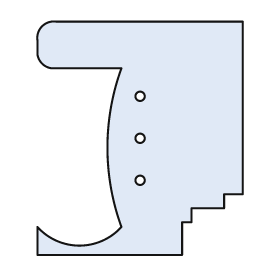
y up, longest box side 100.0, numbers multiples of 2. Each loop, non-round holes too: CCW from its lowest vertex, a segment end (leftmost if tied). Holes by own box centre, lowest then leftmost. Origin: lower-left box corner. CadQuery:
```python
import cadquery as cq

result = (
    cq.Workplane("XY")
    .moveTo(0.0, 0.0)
    .lineTo(62.0, 0.0)
    .lineTo(62.0, 14.0)
    .lineTo(66.0, 14.0)
    .lineTo(66.0, 20.0)
    .lineTo(80.0, 20.0)
    .lineTo(80.0, 26.0)
    .lineTo(88.0, 26.0)
    .lineTo(88.0, 100.0)
    .lineTo(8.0, 100.0)
    .threePointArc((2.0, 98.0), (0.0, 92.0))
    .lineTo(0.0, 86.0)
    .threePointArc((2.0, 82.0), (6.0, 80.0))
    .lineTo(36.0, 80.0)
    .threePointArc((30.0, 46.0), (36.0, 12.0))
    .threePointArc((18.0, 4.0), (0.0, 12.0))
    .close()
    .moveTo(44.0, 32.0)
    .circle(2.0)
    .moveTo(44.0, 50.0)
    .circle(2.0)
    .moveTo(44.0, 68.0)
    .circle(2.0)
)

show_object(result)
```